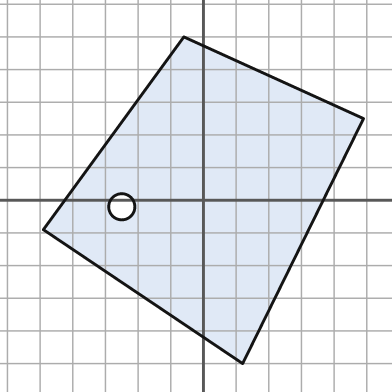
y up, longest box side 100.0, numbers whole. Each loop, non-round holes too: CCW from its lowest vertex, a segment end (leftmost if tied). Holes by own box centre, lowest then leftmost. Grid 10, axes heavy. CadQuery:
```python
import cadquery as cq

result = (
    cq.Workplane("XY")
    .moveTo(12.0, -50.0)
    .lineTo(49.0, 25.0)
    .lineTo(-6.0, 50.0)
    .lineTo(-49.0, -9.0)
    .close()
    .moveTo(-25.0, -2.0)
    .circle(4.0)
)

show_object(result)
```